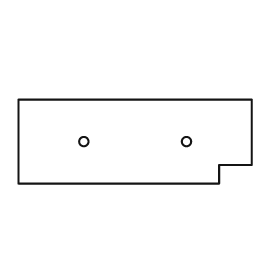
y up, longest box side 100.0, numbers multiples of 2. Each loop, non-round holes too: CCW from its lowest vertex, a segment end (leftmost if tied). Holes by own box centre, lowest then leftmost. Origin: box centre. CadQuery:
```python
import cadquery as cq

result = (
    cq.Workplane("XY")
    .moveTo(-50.0, -18.0)
    .lineTo(36.0, -18.0)
    .lineTo(36.0, -10.0)
    .lineTo(50.0, -10.0)
    .lineTo(50.0, 18.0)
    .lineTo(-50.0, 18.0)
    .close()
    .moveTo(-22.0, 0.0)
    .circle(2.0)
    .moveTo(22.0, 0.0)
    .circle(2.0)
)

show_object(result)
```